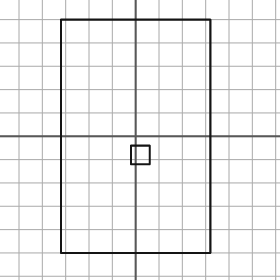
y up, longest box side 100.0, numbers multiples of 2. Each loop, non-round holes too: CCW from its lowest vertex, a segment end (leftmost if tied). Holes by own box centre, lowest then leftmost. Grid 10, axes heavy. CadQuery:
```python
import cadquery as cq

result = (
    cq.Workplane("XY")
    .moveTo(-32.0, -50.0)
    .lineTo(32.0, -50.0)
    .lineTo(32.0, 50.0)
    .lineTo(-32.0, 50.0)
    .close()
    .moveTo(-2.0, -12.0)
    .lineTo(6.0, -12.0)
    .lineTo(6.0, -4.0)
    .lineTo(-2.0, -4.0)
    .close()
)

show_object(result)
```